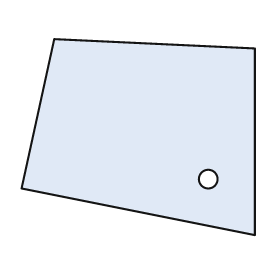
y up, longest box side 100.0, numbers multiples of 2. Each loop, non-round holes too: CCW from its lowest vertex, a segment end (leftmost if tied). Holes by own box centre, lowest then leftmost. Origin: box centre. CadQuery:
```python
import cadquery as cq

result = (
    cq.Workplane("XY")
    .moveTo(50.0, -42.0)
    .lineTo(50.0, 38.0)
    .lineTo(-36.0, 42.0)
    .lineTo(-50.0, -22.0)
    .close()
    .moveTo(30.0, -18.0)
    .circle(4.0)
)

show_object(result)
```